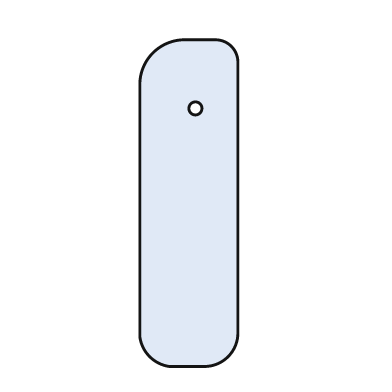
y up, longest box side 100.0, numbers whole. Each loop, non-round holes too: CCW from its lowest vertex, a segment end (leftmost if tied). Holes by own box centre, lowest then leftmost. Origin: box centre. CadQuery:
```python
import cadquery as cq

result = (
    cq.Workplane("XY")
    .moveTo(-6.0, -50.0)
    .lineTo(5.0, -50.0)
    .threePointArc((12.0, -47.0), (15.0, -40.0))
    .lineTo(15.0, 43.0)
    .threePointArc((13.0, 48.0), (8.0, 50.0))
    .lineTo(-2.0, 50.0)
    .threePointArc((-11.0, 46.0), (-15.0, 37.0))
    .lineTo(-15.0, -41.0)
    .threePointArc((-12.0, -47.0), (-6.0, -50.0))
    .close()
    .moveTo(2.0, 29.0)
    .circle(2.0)
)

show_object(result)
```